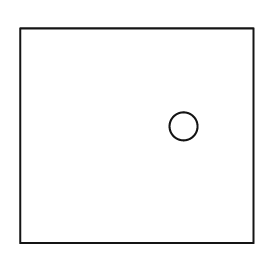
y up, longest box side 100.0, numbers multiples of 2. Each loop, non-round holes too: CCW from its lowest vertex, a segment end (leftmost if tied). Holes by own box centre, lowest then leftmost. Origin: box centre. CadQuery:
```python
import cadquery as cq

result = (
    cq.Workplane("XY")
    .moveTo(-50.0, -46.0)
    .lineTo(50.0, -46.0)
    .lineTo(50.0, 46.0)
    .lineTo(-50.0, 46.0)
    .close()
    .moveTo(20.0, 4.0)
    .circle(6.0)
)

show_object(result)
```